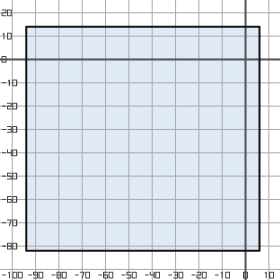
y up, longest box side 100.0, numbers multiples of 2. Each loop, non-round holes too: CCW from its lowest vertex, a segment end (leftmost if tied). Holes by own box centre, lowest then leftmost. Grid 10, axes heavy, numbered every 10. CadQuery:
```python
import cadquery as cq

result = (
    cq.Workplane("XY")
    .moveTo(-94.0, -82.0)
    .lineTo(6.0, -82.0)
    .lineTo(6.0, 14.0)
    .lineTo(-94.0, 14.0)
    .close()
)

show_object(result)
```